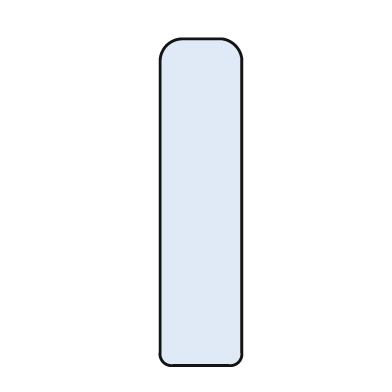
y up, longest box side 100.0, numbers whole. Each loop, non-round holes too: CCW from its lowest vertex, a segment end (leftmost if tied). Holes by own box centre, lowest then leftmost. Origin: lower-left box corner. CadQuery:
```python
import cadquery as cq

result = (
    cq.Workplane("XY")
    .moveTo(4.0, 0.0)
    .lineTo(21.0, 0.0)
    .threePointArc((24.0, 1.0), (25.0, 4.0))
    .lineTo(25.0, 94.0)
    .threePointArc((23.0, 98.0), (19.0, 100.0))
    .lineTo(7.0, 100.0)
    .threePointArc((2.0, 98.0), (0.0, 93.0))
    .lineTo(0.0, 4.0)
    .threePointArc((1.0, 1.0), (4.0, 0.0))
    .close()
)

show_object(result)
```